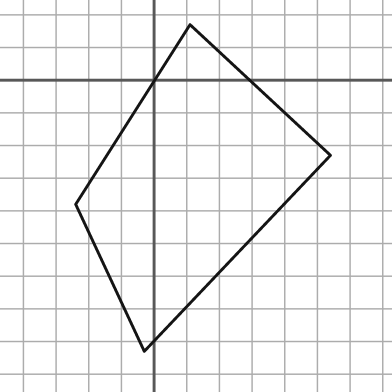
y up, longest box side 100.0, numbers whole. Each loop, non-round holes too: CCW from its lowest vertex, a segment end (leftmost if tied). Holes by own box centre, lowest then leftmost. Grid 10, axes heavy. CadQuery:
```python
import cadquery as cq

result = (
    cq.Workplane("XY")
    .moveTo(-3.0, -83.0)
    .lineTo(54.0, -23.0)
    .lineTo(11.0, 17.0)
    .lineTo(-24.0, -38.0)
    .close()
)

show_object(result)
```